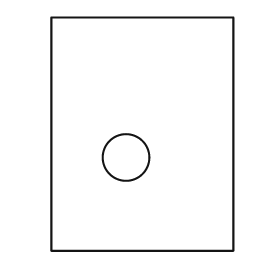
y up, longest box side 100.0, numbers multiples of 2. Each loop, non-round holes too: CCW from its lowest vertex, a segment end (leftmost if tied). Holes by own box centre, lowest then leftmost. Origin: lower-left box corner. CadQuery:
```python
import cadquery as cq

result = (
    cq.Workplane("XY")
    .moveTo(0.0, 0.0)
    .lineTo(78.0, 0.0)
    .lineTo(78.0, 100.0)
    .lineTo(0.0, 100.0)
    .close()
    .moveTo(32.0, 40.0)
    .circle(10.0)
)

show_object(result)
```